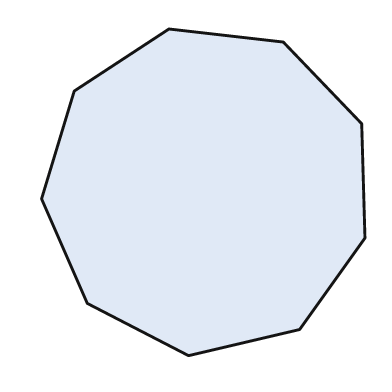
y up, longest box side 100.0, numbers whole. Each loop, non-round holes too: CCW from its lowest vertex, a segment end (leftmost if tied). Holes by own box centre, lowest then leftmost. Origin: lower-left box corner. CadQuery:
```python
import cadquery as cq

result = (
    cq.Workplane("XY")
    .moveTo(45.0, 0.0)
    .lineTo(79.0, 8.0)
    .lineTo(99.0, 36.0)
    .lineTo(98.0, 71.0)
    .lineTo(74.0, 96.0)
    .lineTo(39.0, 100.0)
    .lineTo(10.0, 81.0)
    .lineTo(0.0, 48.0)
    .lineTo(14.0, 16.0)
    .close()
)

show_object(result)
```